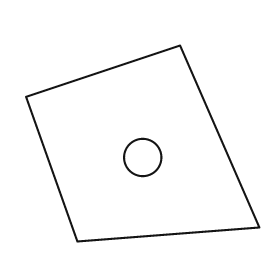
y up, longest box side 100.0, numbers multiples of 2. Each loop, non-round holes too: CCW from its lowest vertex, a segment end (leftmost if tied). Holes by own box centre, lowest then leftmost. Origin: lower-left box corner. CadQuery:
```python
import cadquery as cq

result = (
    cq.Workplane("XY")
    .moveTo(22.0, 0.0)
    .lineTo(100.0, 6.0)
    .lineTo(66.0, 84.0)
    .lineTo(0.0, 62.0)
    .close()
    .moveTo(50.0, 36.0)
    .circle(8.0)
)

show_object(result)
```